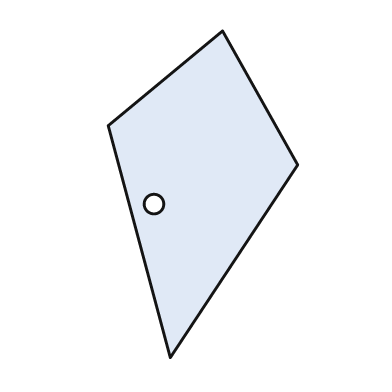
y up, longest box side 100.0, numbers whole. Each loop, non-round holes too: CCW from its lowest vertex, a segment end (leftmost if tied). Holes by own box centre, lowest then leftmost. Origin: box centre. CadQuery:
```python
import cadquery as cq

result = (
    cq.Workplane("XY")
    .moveTo(-10.0, -50.0)
    .lineTo(29.0, 9.0)
    .lineTo(6.0, 50.0)
    .lineTo(-29.0, 21.0)
    .close()
    .moveTo(-15.0, -3.0)
    .circle(3.0)
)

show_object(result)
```